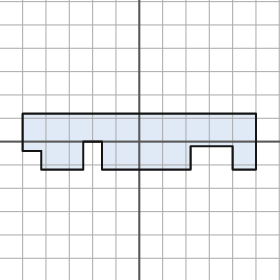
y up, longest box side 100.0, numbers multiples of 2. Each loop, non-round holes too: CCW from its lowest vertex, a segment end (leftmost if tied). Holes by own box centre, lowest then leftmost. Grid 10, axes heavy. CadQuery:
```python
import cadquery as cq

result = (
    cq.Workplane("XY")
    .moveTo(-42.0, -12.0)
    .lineTo(-24.0, -12.0)
    .lineTo(-24.0, 0.0)
    .lineTo(-16.0, 0.0)
    .lineTo(-16.0, -12.0)
    .lineTo(22.0, -12.0)
    .lineTo(22.0, -2.0)
    .lineTo(40.0, -2.0)
    .lineTo(40.0, -12.0)
    .lineTo(50.0, -12.0)
    .lineTo(50.0, 12.0)
    .lineTo(-50.0, 12.0)
    .lineTo(-50.0, -4.0)
    .lineTo(-42.0, -4.0)
    .close()
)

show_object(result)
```